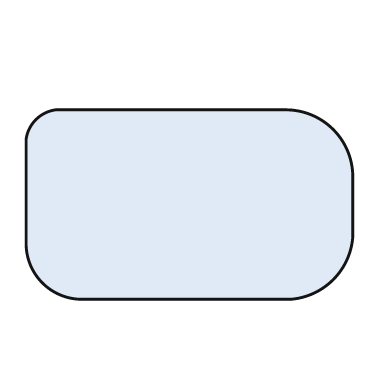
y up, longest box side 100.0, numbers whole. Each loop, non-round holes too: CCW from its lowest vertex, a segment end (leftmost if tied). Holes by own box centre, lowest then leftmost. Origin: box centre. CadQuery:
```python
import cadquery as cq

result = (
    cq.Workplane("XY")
    .moveTo(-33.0, -29.0)
    .lineTo(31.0, -29.0)
    .threePointArc((44.0, -23.0), (50.0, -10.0))
    .lineTo(50.0, 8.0)
    .threePointArc((44.0, 23.0), (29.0, 29.0))
    .lineTo(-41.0, 29.0)
    .threePointArc((-47.0, 26.0), (-50.0, 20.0))
    .lineTo(-50.0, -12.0)
    .threePointArc((-45.0, -24.0), (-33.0, -29.0))
    .close()
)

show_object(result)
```